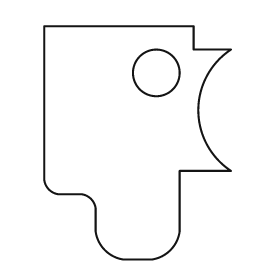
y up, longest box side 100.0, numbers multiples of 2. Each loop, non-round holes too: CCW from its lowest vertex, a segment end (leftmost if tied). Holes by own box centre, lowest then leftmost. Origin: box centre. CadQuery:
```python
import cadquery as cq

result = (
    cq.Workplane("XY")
    .moveTo(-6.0, -50.0)
    .lineTo(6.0, -50.0)
    .threePointArc((14.0, -46.0), (18.0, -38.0))
    .lineTo(18.0, -12.0)
    .lineTo(40.0, -12.0)
    .threePointArc((26.0, 14.0), (40.0, 40.0))
    .lineTo(24.0, 40.0)
    .lineTo(24.0, 50.0)
    .lineTo(-40.0, 50.0)
    .lineTo(-40.0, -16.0)
    .threePointArc((-38.0, -20.0), (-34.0, -22.0))
    .lineTo(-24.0, -22.0)
    .threePointArc((-20.0, -24.0), (-18.0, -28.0))
    .lineTo(-18.0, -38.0)
    .threePointArc((-14.0, -46.0), (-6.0, -50.0))
    .close()
    .moveTo(8.0, 30.0)
    .circle(10.0)
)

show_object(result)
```